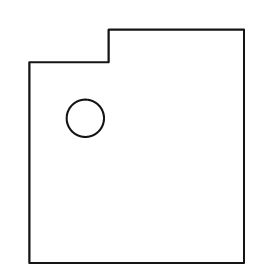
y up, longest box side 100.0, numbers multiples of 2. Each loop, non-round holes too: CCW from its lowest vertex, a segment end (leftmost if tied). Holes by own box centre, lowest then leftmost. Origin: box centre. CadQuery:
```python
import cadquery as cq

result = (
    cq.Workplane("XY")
    .moveTo(-46.0, -50.0)
    .lineTo(46.0, -50.0)
    .lineTo(46.0, 50.0)
    .lineTo(-12.0, 50.0)
    .lineTo(-12.0, 36.0)
    .lineTo(-46.0, 36.0)
    .close()
    .moveTo(-22.0, 12.0)
    .circle(8.0)
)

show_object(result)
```